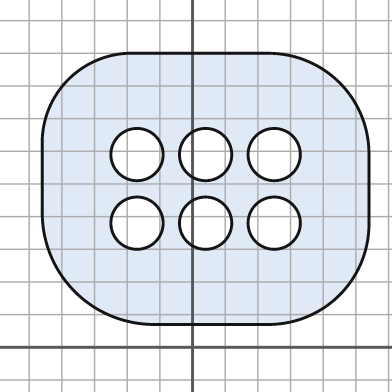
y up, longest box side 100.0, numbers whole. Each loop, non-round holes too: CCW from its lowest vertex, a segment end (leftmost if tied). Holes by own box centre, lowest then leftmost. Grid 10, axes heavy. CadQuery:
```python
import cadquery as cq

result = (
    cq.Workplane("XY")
    .moveTo(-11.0, 7.0)
    .lineTo(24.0, 7.0)
    .threePointArc((45.0, 16.0), (54.0, 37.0))
    .lineTo(54.0, 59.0)
    .threePointArc((45.0, 81.0), (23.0, 90.0))
    .lineTo(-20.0, 90.0)
    .threePointArc((-38.0, 82.0), (-46.0, 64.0))
    .lineTo(-46.0, 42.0)
    .threePointArc((-36.0, 17.0), (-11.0, 7.0))
    .close()
    .moveTo(-17.0, 38.0)
    .circle(8.0)
    .moveTo(4.0, 38.0)
    .circle(8.0)
    .moveTo(25.0, 38.0)
    .circle(8.0)
    .moveTo(-17.0, 59.0)
    .circle(8.0)
    .moveTo(4.0, 59.0)
    .circle(8.0)
    .moveTo(25.0, 59.0)
    .circle(8.0)
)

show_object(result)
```